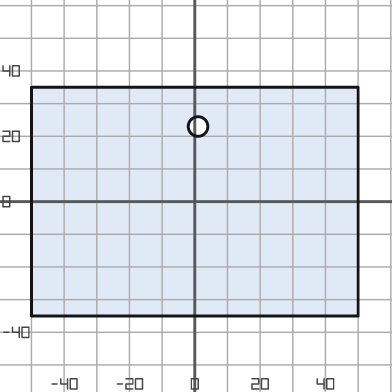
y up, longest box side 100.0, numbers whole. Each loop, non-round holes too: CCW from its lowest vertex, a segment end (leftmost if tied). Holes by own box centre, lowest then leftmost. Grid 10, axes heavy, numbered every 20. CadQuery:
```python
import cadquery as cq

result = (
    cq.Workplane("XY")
    .moveTo(-50.0, -35.0)
    .lineTo(50.0, -35.0)
    .lineTo(50.0, 35.0)
    .lineTo(-50.0, 35.0)
    .close()
    .moveTo(1.0, 23.0)
    .circle(3.0)
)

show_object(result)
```